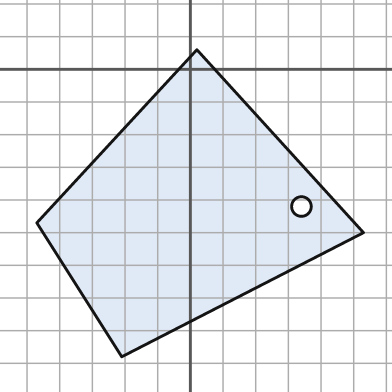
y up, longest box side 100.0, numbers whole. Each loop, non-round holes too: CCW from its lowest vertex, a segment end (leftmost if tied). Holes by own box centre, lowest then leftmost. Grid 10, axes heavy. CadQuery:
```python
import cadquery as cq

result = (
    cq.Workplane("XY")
    .moveTo(-21.0, -88.0)
    .lineTo(53.0, -50.0)
    .lineTo(2.0, 6.0)
    .lineTo(-47.0, -47.0)
    .close()
    .moveTo(34.0, -42.0)
    .circle(3.0)
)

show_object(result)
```